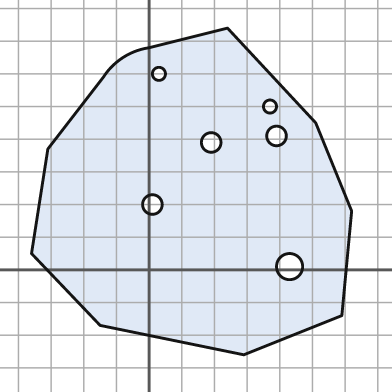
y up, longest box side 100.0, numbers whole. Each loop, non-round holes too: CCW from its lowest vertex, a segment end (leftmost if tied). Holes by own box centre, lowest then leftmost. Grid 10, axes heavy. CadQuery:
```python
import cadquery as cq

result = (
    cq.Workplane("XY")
    .moveTo(29.0, -26.0)
    .lineTo(59.0, -14.0)
    .lineTo(62.0, 18.0)
    .lineTo(51.0, 45.0)
    .lineTo(24.0, 74.0)
    .lineTo(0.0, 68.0)
    .threePointArc((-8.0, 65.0), (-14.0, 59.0))
    .lineTo(-31.0, 37.0)
    .lineTo(-36.0, 5.0)
    .lineTo(-15.0, -17.0)
    .close()
    .moveTo(43.0, 1.0)
    .circle(4.0)
    .moveTo(1.0, 20.0)
    .circle(3.0)
    .moveTo(19.0, 39.0)
    .circle(3.0)
    .moveTo(39.0, 41.0)
    .circle(3.0)
    .moveTo(37.0, 50.0)
    .circle(2.0)
    .moveTo(3.0, 60.0)
    .circle(2.0)
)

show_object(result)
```